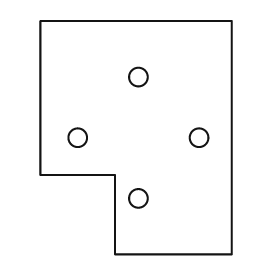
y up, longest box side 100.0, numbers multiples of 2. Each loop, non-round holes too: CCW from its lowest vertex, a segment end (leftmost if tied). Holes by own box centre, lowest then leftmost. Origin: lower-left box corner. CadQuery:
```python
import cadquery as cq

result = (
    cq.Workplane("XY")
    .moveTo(32.0, 0.0)
    .lineTo(82.0, 0.0)
    .lineTo(82.0, 100.0)
    .lineTo(0.0, 100.0)
    .lineTo(0.0, 34.0)
    .lineTo(32.0, 34.0)
    .close()
    .moveTo(42.0, 24.0)
    .circle(4.0)
    .moveTo(16.0, 50.0)
    .circle(4.0)
    .moveTo(68.0, 50.0)
    .circle(4.0)
    .moveTo(42.0, 76.0)
    .circle(4.0)
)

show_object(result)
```